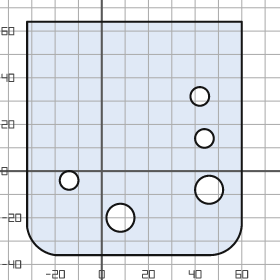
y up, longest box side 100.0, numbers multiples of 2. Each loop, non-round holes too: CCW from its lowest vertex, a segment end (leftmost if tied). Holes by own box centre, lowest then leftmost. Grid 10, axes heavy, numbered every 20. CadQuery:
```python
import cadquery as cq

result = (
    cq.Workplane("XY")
    .moveTo(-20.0, -36.0)
    .lineTo(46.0, -36.0)
    .threePointArc((56.0, -32.0), (60.0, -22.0))
    .lineTo(60.0, 64.0)
    .lineTo(-32.0, 64.0)
    .lineTo(-32.0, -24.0)
    .threePointArc((-28.0, -32.0), (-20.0, -36.0))
    .close()
    .moveTo(8.0, -20.0)
    .circle(6.0)
    .moveTo(46.0, -8.0)
    .circle(6.0)
    .moveTo(-14.0, -4.0)
    .circle(4.0)
    .moveTo(44.0, 14.0)
    .circle(4.0)
    .moveTo(42.0, 32.0)
    .circle(4.0)
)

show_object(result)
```